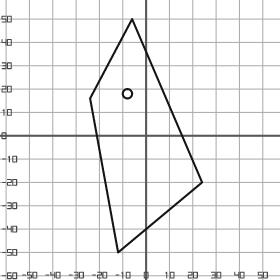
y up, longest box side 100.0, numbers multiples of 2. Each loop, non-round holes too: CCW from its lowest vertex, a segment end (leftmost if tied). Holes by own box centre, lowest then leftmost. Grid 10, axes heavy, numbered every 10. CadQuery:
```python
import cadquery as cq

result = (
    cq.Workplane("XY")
    .moveTo(-12.0, -50.0)
    .lineTo(24.0, -20.0)
    .lineTo(-6.0, 50.0)
    .lineTo(-24.0, 16.0)
    .close()
    .moveTo(-8.0, 18.0)
    .circle(2.0)
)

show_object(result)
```